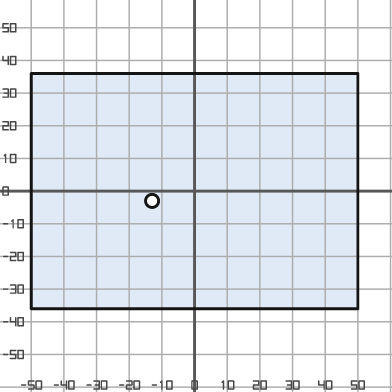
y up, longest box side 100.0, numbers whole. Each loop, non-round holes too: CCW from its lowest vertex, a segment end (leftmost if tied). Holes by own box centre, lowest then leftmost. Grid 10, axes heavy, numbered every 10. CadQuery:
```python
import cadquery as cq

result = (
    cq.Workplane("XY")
    .moveTo(-50.0, -36.0)
    .lineTo(50.0, -36.0)
    .lineTo(50.0, 36.0)
    .lineTo(-50.0, 36.0)
    .close()
    .moveTo(-13.0, -3.0)
    .circle(2.0)
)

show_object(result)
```